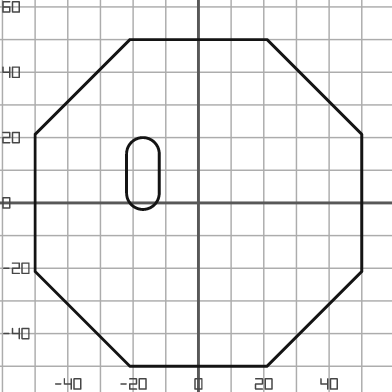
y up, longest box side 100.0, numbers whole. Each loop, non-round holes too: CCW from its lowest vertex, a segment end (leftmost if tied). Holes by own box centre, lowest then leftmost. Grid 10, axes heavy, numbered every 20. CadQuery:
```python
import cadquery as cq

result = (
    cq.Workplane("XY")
    .moveTo(-21.0, -50.0)
    .lineTo(21.0, -50.0)
    .lineTo(50.0, -21.0)
    .lineTo(50.0, 21.0)
    .lineTo(21.0, 50.0)
    .lineTo(-21.0, 50.0)
    .lineTo(-50.0, 21.0)
    .lineTo(-50.0, -21.0)
    .close()
    .moveTo(-22.0, 3.0)
    .threePointArc((-17.0, -2.0), (-12.0, 3.0))
    .lineTo(-12.0, 15.0)
    .threePointArc((-17.0, 20.0), (-22.0, 15.0))
    .close()
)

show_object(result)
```